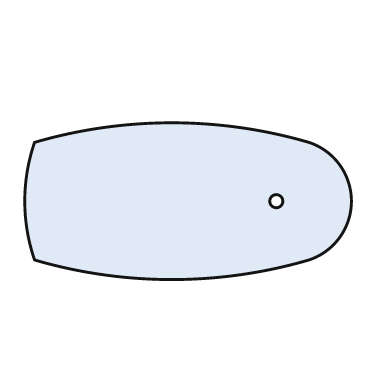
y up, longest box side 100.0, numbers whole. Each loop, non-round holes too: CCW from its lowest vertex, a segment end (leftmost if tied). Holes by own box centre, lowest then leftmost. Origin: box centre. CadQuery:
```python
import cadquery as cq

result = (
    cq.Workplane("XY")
    .moveTo(-47.0, -18.0)
    .threePointArc((-5.0, -24.0), (37.0, -18.0))
    .threePointArc((50.0, 0.0), (37.0, 18.0))
    .threePointArc((-5.0, 24.0), (-47.0, 18.0))
    .threePointArc((-50.0, 0.0), (-47.0, -18.0))
    .close()
    .moveTo(27.0, 0.0)
    .circle(2.0)
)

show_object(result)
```